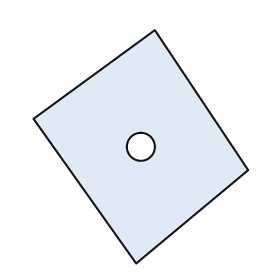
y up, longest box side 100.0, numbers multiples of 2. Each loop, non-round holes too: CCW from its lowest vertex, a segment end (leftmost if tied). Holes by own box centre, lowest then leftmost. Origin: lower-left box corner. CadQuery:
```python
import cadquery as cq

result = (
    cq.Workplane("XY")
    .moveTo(44.0, 0.0)
    .lineTo(92.0, 40.0)
    .lineTo(52.0, 100.0)
    .lineTo(0.0, 62.0)
    .close()
    .moveTo(46.0, 50.0)
    .circle(6.0)
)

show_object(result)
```